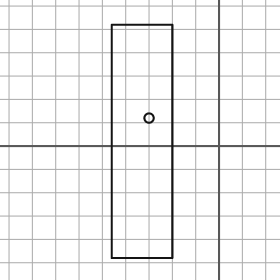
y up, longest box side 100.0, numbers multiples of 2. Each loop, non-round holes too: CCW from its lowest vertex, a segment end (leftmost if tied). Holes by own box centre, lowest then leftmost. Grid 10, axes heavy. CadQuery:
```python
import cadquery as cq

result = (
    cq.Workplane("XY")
    .moveTo(-46.0, -48.0)
    .lineTo(-20.0, -48.0)
    .lineTo(-20.0, 52.0)
    .lineTo(-46.0, 52.0)
    .close()
    .moveTo(-30.0, 12.0)
    .circle(2.0)
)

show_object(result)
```